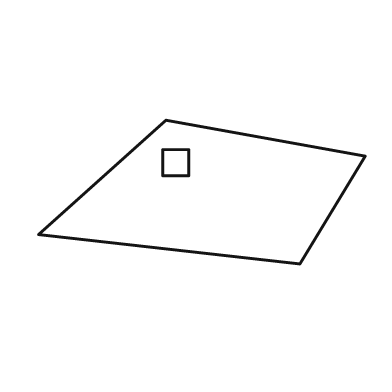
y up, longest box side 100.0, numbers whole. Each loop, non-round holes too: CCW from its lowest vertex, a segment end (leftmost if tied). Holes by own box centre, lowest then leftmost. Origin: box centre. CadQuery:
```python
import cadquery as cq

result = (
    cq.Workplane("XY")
    .moveTo(30.0, -22.0)
    .lineTo(50.0, 11.0)
    .lineTo(-11.0, 22.0)
    .lineTo(-50.0, -13.0)
    .close()
    .moveTo(-12.0, 5.0)
    .lineTo(-4.0, 5.0)
    .lineTo(-4.0, 13.0)
    .lineTo(-12.0, 13.0)
    .close()
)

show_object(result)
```